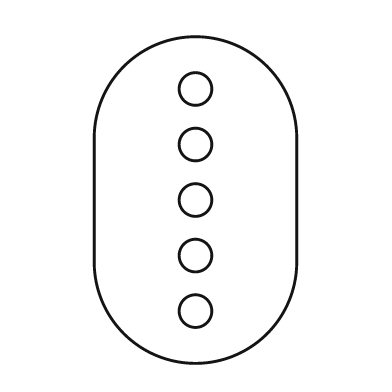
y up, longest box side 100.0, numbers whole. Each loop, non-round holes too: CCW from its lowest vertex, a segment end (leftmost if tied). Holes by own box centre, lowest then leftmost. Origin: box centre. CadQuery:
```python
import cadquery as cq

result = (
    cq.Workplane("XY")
    .moveTo(-31.0, -19.0)
    .threePointArc((0.0, -50.0), (31.0, -19.0))
    .lineTo(31.0, 19.0)
    .threePointArc((0.0, 50.0), (-31.0, 19.0))
    .close()
    .moveTo(0.0, -34.0)
    .circle(5.0)
    .moveTo(0.0, -17.0)
    .circle(5.0)
    .moveTo(0.0, 0.0)
    .circle(5.0)
    .moveTo(0.0, 17.0)
    .circle(5.0)
    .moveTo(0.0, 34.0)
    .circle(5.0)
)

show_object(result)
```